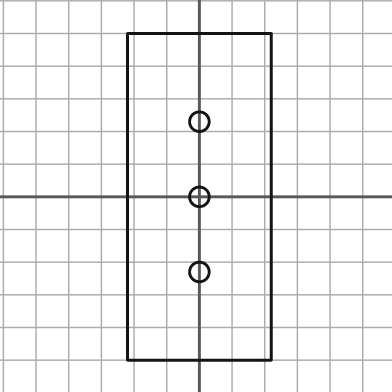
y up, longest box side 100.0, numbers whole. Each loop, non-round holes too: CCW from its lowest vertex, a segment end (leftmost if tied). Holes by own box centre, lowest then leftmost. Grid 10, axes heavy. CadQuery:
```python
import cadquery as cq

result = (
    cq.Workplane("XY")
    .moveTo(-22.0, -50.0)
    .lineTo(22.0, -50.0)
    .lineTo(22.0, 50.0)
    .lineTo(-22.0, 50.0)
    .close()
    .moveTo(0.0, -23.0)
    .circle(3.0)
    .moveTo(0.0, 0.0)
    .circle(3.0)
    .moveTo(0.0, 23.0)
    .circle(3.0)
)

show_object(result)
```